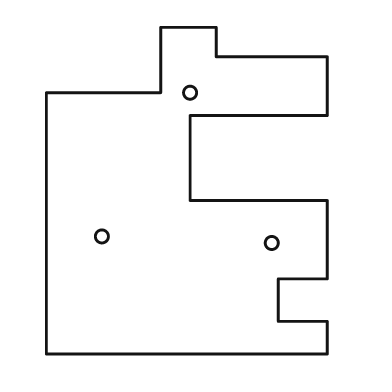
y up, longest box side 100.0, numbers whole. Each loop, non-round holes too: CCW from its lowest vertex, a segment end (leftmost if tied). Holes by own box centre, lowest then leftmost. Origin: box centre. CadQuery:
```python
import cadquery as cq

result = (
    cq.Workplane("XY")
    .moveTo(-43.0, -50.0)
    .lineTo(43.0, -50.0)
    .lineTo(43.0, -40.0)
    .lineTo(28.0, -40.0)
    .lineTo(28.0, -27.0)
    .lineTo(43.0, -27.0)
    .lineTo(43.0, -3.0)
    .lineTo(1.0, -3.0)
    .lineTo(1.0, 23.0)
    .lineTo(43.0, 23.0)
    .lineTo(43.0, 41.0)
    .lineTo(9.0, 41.0)
    .lineTo(9.0, 50.0)
    .lineTo(-8.0, 50.0)
    .lineTo(-8.0, 30.0)
    .lineTo(-43.0, 30.0)
    .close()
    .moveTo(26.0, -16.0)
    .circle(2.0)
    .moveTo(-26.0, -14.0)
    .circle(2.0)
    .moveTo(1.0, 30.0)
    .circle(2.0)
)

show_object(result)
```